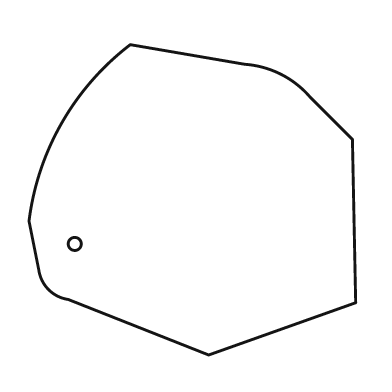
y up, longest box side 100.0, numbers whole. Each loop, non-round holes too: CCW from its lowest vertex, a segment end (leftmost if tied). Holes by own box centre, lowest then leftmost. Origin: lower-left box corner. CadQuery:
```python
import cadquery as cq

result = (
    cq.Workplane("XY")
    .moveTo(55.0, 0.0)
    .lineTo(100.0, 16.0)
    .lineTo(99.0, 66.0)
    .lineTo(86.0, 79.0)
    .threePointArc((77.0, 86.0), (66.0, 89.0))
    .lineTo(31.0, 95.0)
    .threePointArc((10.0, 71.0), (0.0, 41.0))
    .lineTo(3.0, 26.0)
    .threePointArc((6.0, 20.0), (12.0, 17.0))
    .close()
    .moveTo(14.0, 34.0)
    .circle(2.0)
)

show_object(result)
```